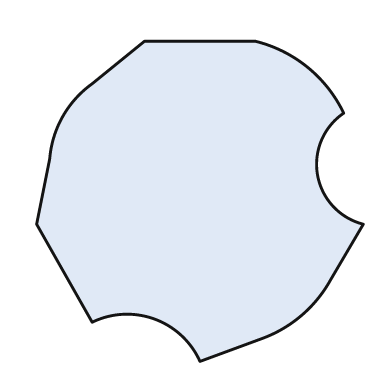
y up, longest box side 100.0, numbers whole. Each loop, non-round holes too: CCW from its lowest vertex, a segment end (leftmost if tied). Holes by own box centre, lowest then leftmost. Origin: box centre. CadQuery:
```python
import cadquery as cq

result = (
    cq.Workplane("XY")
    .moveTo(0.0, -49.0)
    .lineTo(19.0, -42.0)
    .threePointArc((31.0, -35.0), (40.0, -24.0))
    .lineTo(50.0, -7.0)
    .threePointArc((36.0, 8.0), (44.0, 27.0))
    .threePointArc((33.0, 41.0), (17.0, 49.0))
    .lineTo(-17.0, 49.0)
    .lineTo(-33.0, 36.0)
    .threePointArc((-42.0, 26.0), (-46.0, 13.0))
    .lineTo(-50.0, -7.0)
    .lineTo(-33.0, -37.0)
    .threePointArc((-14.0, -36.0), (0.0, -49.0))
    .close()
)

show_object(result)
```